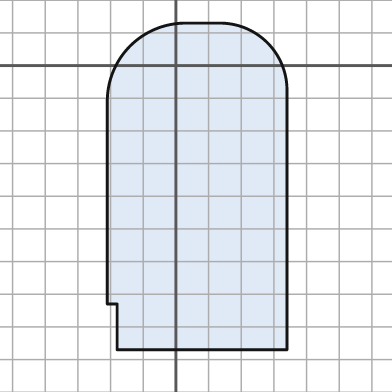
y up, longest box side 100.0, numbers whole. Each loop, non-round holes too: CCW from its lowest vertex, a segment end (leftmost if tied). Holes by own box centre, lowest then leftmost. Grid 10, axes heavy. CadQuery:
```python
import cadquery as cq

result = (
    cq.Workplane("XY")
    .moveTo(-18.0, -87.0)
    .lineTo(34.0, -87.0)
    .lineTo(34.0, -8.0)
    .threePointArc((28.0, 7.0), (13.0, 13.0))
    .lineTo(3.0, 13.0)
    .threePointArc((-14.0, 6.0), (-21.0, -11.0))
    .lineTo(-21.0, -73.0)
    .lineTo(-18.0, -73.0)
    .close()
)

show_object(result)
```